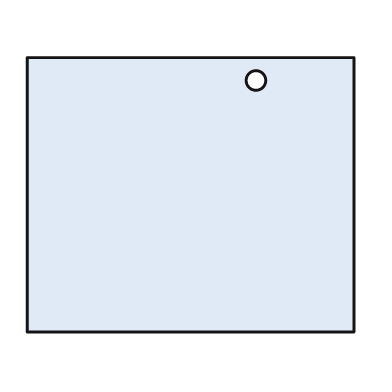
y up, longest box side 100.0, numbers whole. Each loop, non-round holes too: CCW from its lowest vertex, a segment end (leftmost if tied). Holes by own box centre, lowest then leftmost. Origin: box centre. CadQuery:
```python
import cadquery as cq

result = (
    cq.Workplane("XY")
    .moveTo(-50.0, -42.0)
    .lineTo(50.0, -42.0)
    .lineTo(50.0, 42.0)
    .lineTo(-50.0, 42.0)
    .close()
    .moveTo(20.0, 35.0)
    .circle(3.0)
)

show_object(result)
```